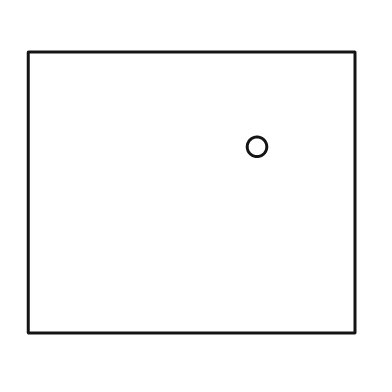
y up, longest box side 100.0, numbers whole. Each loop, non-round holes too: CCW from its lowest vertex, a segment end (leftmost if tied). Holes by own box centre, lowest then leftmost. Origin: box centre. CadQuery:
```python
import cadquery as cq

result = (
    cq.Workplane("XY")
    .moveTo(-50.0, -43.0)
    .lineTo(50.0, -43.0)
    .lineTo(50.0, 43.0)
    .lineTo(-50.0, 43.0)
    .close()
    .moveTo(20.0, 14.0)
    .circle(3.0)
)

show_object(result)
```